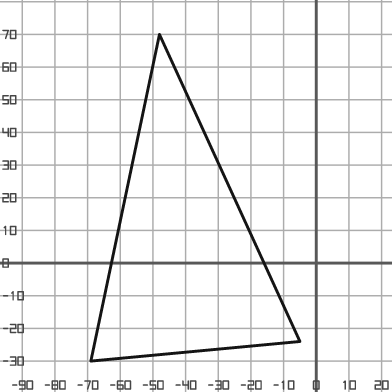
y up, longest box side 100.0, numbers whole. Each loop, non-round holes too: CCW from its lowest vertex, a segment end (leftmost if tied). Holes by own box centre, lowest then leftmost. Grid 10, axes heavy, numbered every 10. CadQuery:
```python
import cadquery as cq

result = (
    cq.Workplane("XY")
    .moveTo(-69.0, -30.0)
    .lineTo(-5.0, -24.0)
    .lineTo(-48.0, 70.0)
    .close()
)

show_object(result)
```